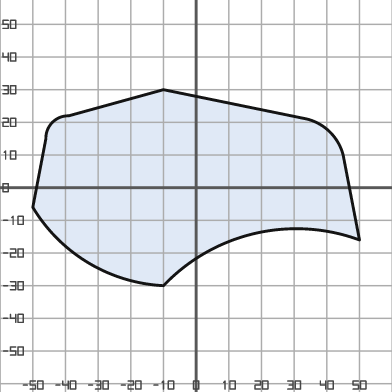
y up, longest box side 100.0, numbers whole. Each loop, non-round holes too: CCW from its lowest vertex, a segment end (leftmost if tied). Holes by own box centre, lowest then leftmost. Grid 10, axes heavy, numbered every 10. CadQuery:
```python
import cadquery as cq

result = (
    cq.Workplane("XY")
    .moveTo(-10.0, -30.0)
    .threePointArc((18.0, -14.0), (50.0, -16.0))
    .lineTo(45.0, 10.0)
    .threePointArc((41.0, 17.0), (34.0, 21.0))
    .lineTo(-10.0, 30.0)
    .lineTo(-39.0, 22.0)
    .threePointArc((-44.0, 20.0), (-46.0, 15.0))
    .lineTo(-50.0, -6.0)
    .threePointArc((-33.0, -23.0), (-10.0, -30.0))
    .close()
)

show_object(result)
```